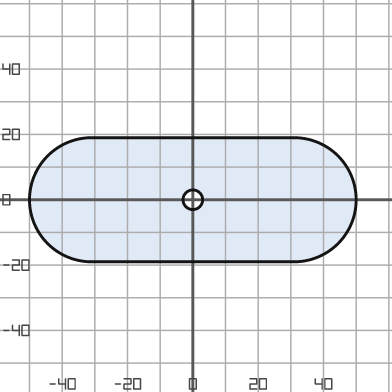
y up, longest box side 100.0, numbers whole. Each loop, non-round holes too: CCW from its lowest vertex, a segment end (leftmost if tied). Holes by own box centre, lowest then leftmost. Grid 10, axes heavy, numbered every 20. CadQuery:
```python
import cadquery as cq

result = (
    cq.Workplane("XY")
    .moveTo(-31.0, -19.0)
    .lineTo(31.0, -19.0)
    .threePointArc((50.0, 0.0), (31.0, 19.0))
    .lineTo(-31.0, 19.0)
    .threePointArc((-50.0, 0.0), (-31.0, -19.0))
    .close()
    .moveTo(0.0, 0.0)
    .circle(3.0)
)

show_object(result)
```